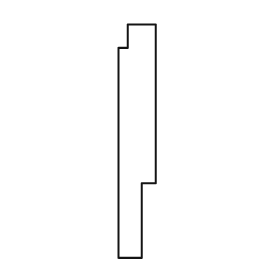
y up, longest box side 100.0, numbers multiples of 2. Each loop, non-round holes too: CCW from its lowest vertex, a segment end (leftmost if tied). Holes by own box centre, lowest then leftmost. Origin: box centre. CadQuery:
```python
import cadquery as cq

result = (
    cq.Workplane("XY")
    .moveTo(-8.0, -50.0)
    .lineTo(2.0, -50.0)
    .lineTo(2.0, -18.0)
    .lineTo(8.0, -18.0)
    .lineTo(8.0, 50.0)
    .lineTo(-4.0, 50.0)
    .lineTo(-4.0, 40.0)
    .lineTo(-8.0, 40.0)
    .close()
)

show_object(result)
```